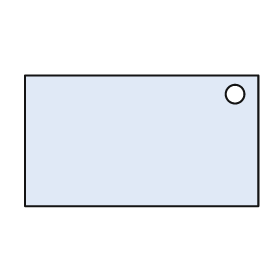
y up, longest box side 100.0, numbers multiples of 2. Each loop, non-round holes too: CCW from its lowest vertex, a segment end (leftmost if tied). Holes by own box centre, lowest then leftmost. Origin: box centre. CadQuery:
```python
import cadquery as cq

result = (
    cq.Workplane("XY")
    .moveTo(-50.0, -28.0)
    .lineTo(50.0, -28.0)
    .lineTo(50.0, 28.0)
    .lineTo(-50.0, 28.0)
    .close()
    .moveTo(40.0, 20.0)
    .circle(4.0)
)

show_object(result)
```